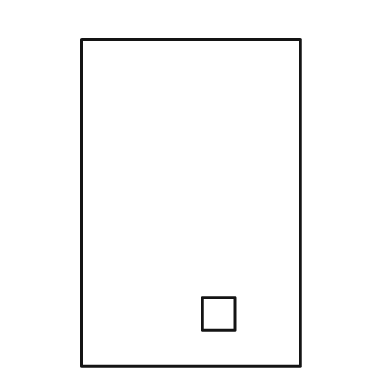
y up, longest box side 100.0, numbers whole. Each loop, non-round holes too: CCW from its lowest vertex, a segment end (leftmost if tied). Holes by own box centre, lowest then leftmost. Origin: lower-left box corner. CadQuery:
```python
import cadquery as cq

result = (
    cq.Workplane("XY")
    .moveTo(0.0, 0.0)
    .lineTo(67.0, 0.0)
    .lineTo(67.0, 100.0)
    .lineTo(0.0, 100.0)
    .close()
    .moveTo(37.0, 11.0)
    .lineTo(47.0, 11.0)
    .lineTo(47.0, 21.0)
    .lineTo(37.0, 21.0)
    .close()
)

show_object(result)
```